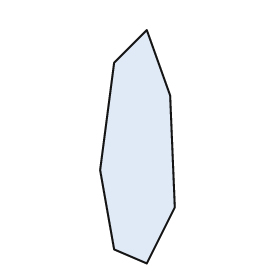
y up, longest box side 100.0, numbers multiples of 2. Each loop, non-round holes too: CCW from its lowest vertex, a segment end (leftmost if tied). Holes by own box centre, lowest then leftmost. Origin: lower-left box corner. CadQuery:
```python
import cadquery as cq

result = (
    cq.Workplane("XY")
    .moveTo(20.0, 0.0)
    .lineTo(32.0, 24.0)
    .lineTo(30.0, 72.0)
    .lineTo(20.0, 100.0)
    .lineTo(6.0, 86.0)
    .lineTo(0.0, 40.0)
    .lineTo(6.0, 6.0)
    .close()
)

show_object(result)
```